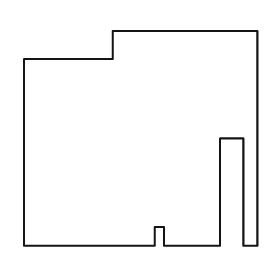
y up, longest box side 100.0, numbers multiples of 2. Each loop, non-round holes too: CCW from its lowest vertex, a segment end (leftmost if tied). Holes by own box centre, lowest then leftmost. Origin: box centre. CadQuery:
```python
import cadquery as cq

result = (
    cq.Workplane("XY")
    .moveTo(-50.0, -46.0)
    .lineTo(6.0, -46.0)
    .lineTo(6.0, -38.0)
    .lineTo(10.0, -38.0)
    .lineTo(10.0, -46.0)
    .lineTo(34.0, -46.0)
    .lineTo(34.0, 0.0)
    .lineTo(44.0, 0.0)
    .lineTo(44.0, -46.0)
    .lineTo(50.0, -46.0)
    .lineTo(50.0, 46.0)
    .lineTo(-12.0, 46.0)
    .lineTo(-12.0, 34.0)
    .lineTo(-50.0, 34.0)
    .close()
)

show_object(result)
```